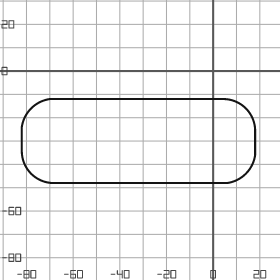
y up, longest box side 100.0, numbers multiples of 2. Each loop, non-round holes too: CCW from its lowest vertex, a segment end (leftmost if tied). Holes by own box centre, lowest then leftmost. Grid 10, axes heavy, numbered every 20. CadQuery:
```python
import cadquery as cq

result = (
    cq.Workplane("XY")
    .moveTo(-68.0, -48.0)
    .lineTo(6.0, -48.0)
    .threePointArc((14.0, -44.0), (18.0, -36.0))
    .lineTo(18.0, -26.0)
    .threePointArc((14.0, -16.0), (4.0, -12.0))
    .lineTo(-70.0, -12.0)
    .threePointArc((-78.0, -16.0), (-82.0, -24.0))
    .lineTo(-82.0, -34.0)
    .threePointArc((-78.0, -44.0), (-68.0, -48.0))
    .close()
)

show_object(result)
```